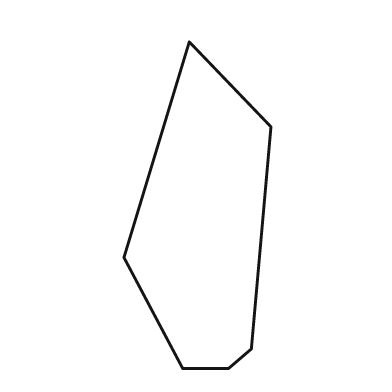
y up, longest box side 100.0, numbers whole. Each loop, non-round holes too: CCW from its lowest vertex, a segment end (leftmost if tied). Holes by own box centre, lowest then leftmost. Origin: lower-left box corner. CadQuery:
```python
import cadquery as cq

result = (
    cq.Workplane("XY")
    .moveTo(18.0, 0.0)
    .lineTo(32.0, 0.0)
    .lineTo(39.0, 6.0)
    .lineTo(45.0, 74.0)
    .lineTo(20.0, 100.0)
    .lineTo(0.0, 34.0)
    .close()
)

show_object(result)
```